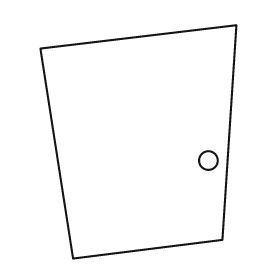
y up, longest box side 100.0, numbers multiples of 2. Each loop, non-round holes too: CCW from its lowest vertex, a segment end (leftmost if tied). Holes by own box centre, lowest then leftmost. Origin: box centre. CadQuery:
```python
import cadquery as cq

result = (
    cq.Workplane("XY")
    .moveTo(-28.0, -50.0)
    .lineTo(36.0, -42.0)
    .lineTo(42.0, 50.0)
    .lineTo(-42.0, 40.0)
    .close()
    .moveTo(30.0, -8.0)
    .circle(4.0)
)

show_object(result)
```